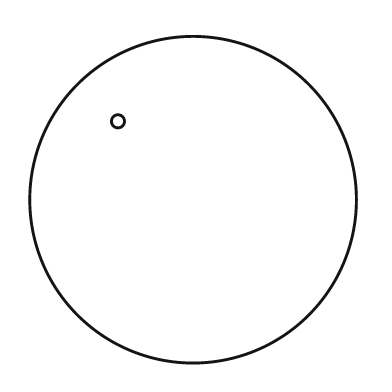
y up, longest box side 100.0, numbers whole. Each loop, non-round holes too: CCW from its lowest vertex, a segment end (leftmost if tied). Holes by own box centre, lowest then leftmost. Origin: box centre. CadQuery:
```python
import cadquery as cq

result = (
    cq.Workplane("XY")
    .moveTo(0.0, 0.0)
    .circle(50.0)
    .moveTo(-23.0, 24.0)
    .circle(2.0)
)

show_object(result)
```